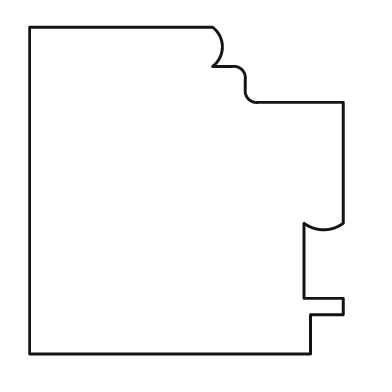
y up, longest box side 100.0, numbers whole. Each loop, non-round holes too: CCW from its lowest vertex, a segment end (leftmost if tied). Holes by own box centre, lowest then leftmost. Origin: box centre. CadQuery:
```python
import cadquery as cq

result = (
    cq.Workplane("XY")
    .moveTo(-48.0, -50.0)
    .lineTo(38.0, -50.0)
    .lineTo(38.0, -38.0)
    .lineTo(48.0, -38.0)
    .lineTo(48.0, -33.0)
    .lineTo(36.0, -33.0)
    .lineTo(36.0, -10.0)
    .threePointArc((42.0, -12.0), (48.0, -10.0))
    .lineTo(48.0, 27.0)
    .lineTo(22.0, 27.0)
    .threePointArc((19.0, 28.0), (18.0, 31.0))
    .lineTo(18.0, 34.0)
    .threePointArc((17.0, 37.0), (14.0, 38.0))
    .lineTo(8.0, 38.0)
    .threePointArc((11.0, 44.0), (8.0, 50.0))
    .lineTo(-48.0, 50.0)
    .close()
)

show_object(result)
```